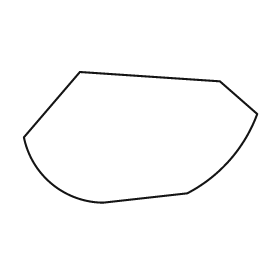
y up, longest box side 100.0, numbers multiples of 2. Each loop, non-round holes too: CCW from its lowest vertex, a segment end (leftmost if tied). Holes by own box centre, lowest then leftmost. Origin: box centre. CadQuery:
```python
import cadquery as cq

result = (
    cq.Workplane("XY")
    .moveTo(-16.0, -28.0)
    .lineTo(20.0, -24.0)
    .threePointArc((38.0, -10.0), (50.0, 10.0))
    .lineTo(34.0, 24.0)
    .lineTo(-26.0, 28.0)
    .lineTo(-50.0, 0.0)
    .threePointArc((-38.0, -20.0), (-16.0, -28.0))
    .close()
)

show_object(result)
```